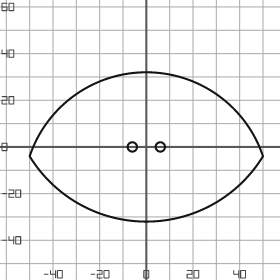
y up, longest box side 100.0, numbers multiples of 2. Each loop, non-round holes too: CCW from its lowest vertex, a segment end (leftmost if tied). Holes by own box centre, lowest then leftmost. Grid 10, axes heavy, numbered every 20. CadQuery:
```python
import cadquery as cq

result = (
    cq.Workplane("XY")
    .moveTo(-50.0, -4.0)
    .threePointArc((0.0, -32.0), (50.0, -4.0))
    .threePointArc((0.0, 32.0), (-50.0, -4.0))
    .close()
    .moveTo(-6.0, 0.0)
    .circle(2.0)
    .moveTo(6.0, 0.0)
    .circle(2.0)
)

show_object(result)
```